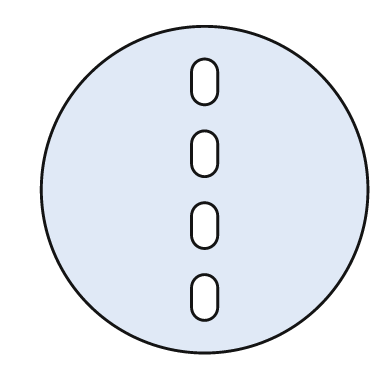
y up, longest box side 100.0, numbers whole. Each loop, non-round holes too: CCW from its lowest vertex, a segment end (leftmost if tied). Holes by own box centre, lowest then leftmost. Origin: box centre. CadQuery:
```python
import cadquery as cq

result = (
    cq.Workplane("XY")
    .moveTo(0.0, 0.0)
    .circle(50.0)
    .moveTo(-4.0, -36.0)
    .threePointArc((0.0, -40.0), (4.0, -36.0))
    .lineTo(4.0, -30.0)
    .threePointArc((0.0, -26.0), (-4.0, -30.0))
    .close()
    .moveTo(-4.0, -14.0)
    .threePointArc((0.0, -18.0), (4.0, -14.0))
    .lineTo(4.0, -8.0)
    .threePointArc((0.0, -4.0), (-4.0, -8.0))
    .close()
    .moveTo(-4.0, 8.0)
    .threePointArc((0.0, 4.0), (4.0, 8.0))
    .lineTo(4.0, 14.0)
    .threePointArc((0.0, 18.0), (-4.0, 14.0))
    .close()
    .moveTo(-4.0, 30.0)
    .threePointArc((0.0, 26.0), (4.0, 30.0))
    .lineTo(4.0, 36.0)
    .threePointArc((0.0, 40.0), (-4.0, 36.0))
    .close()
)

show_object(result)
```